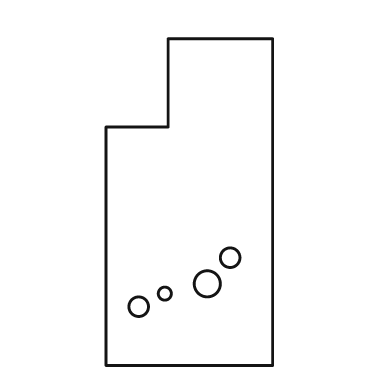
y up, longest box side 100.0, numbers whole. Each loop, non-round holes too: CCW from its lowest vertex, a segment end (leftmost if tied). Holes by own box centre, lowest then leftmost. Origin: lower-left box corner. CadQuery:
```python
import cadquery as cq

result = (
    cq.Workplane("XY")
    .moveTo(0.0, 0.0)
    .lineTo(51.0, 0.0)
    .lineTo(51.0, 100.0)
    .lineTo(19.0, 100.0)
    .lineTo(19.0, 73.0)
    .lineTo(0.0, 73.0)
    .close()
    .moveTo(10.0, 18.0)
    .circle(3.0)
    .moveTo(18.0, 22.0)
    .circle(2.0)
    .moveTo(31.0, 25.0)
    .circle(4.0)
    .moveTo(38.0, 33.0)
    .circle(3.0)
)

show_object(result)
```